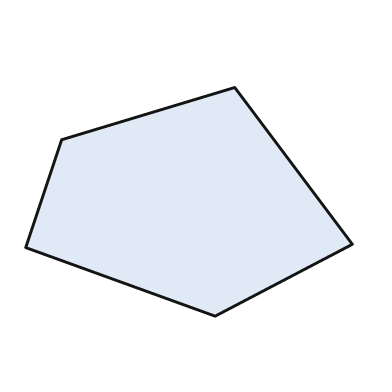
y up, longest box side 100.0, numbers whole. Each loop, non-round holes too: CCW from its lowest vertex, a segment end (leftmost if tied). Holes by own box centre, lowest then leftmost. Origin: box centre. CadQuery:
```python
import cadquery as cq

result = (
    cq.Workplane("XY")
    .moveTo(8.0, -35.0)
    .lineTo(50.0, -13.0)
    .lineTo(14.0, 35.0)
    .lineTo(-39.0, 19.0)
    .lineTo(-50.0, -14.0)
    .close()
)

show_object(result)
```